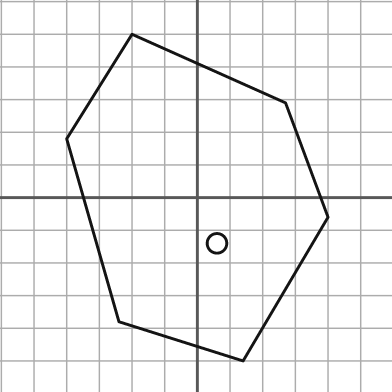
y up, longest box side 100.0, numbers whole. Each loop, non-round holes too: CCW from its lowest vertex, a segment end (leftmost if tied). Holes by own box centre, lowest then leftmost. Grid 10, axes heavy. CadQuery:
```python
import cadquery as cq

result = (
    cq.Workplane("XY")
    .moveTo(14.0, -50.0)
    .lineTo(40.0, -6.0)
    .lineTo(27.0, 29.0)
    .lineTo(-20.0, 50.0)
    .lineTo(-40.0, 18.0)
    .lineTo(-24.0, -38.0)
    .close()
    .moveTo(6.0, -14.0)
    .circle(3.0)
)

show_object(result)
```